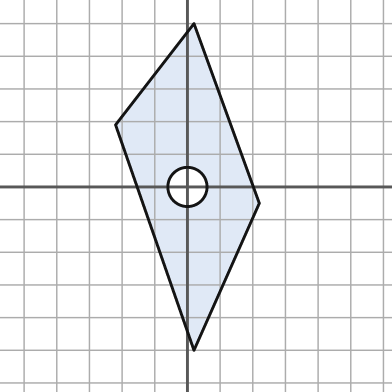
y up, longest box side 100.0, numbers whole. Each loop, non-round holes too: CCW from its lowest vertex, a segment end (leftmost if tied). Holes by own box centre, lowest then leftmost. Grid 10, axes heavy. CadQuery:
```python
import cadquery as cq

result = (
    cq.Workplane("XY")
    .moveTo(2.0, -50.0)
    .lineTo(22.0, -5.0)
    .lineTo(2.0, 50.0)
    .lineTo(-22.0, 19.0)
    .close()
    .moveTo(0.0, 0.0)
    .circle(6.0)
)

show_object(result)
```